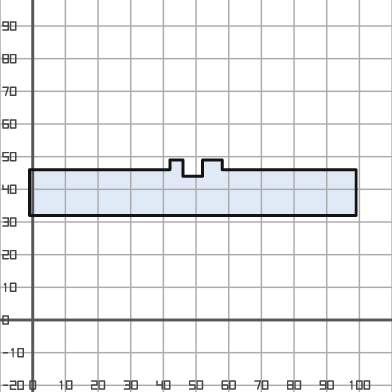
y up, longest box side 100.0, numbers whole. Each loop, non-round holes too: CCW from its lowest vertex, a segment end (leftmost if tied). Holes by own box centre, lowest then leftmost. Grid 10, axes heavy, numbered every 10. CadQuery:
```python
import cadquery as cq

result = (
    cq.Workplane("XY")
    .moveTo(-1.0, 32.0)
    .lineTo(99.0, 32.0)
    .lineTo(99.0, 46.0)
    .lineTo(58.0, 46.0)
    .lineTo(58.0, 49.0)
    .lineTo(52.0, 49.0)
    .lineTo(52.0, 44.0)
    .lineTo(46.0, 44.0)
    .lineTo(46.0, 49.0)
    .lineTo(42.0, 49.0)
    .lineTo(42.0, 46.0)
    .lineTo(-1.0, 46.0)
    .close()
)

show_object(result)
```